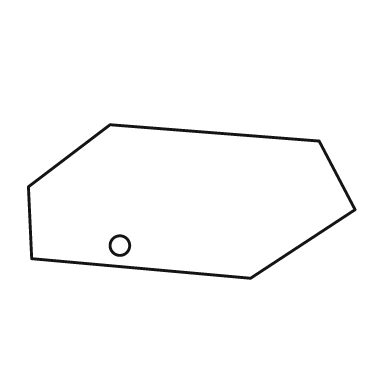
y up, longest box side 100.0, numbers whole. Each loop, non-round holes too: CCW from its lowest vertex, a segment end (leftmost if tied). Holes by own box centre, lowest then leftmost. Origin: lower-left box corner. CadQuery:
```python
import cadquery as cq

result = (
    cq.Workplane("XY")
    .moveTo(68.0, 0.0)
    .lineTo(100.0, 21.0)
    .lineTo(89.0, 42.0)
    .lineTo(25.0, 47.0)
    .lineTo(0.0, 28.0)
    .lineTo(1.0, 6.0)
    .close()
    .moveTo(28.0, 10.0)
    .circle(3.0)
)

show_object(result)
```